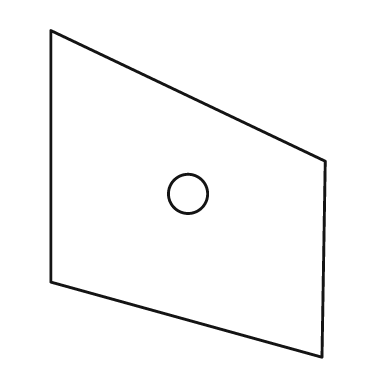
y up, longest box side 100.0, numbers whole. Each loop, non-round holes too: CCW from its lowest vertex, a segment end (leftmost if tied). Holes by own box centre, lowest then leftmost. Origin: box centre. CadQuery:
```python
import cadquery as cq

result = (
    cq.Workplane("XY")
    .moveTo(41.0, -50.0)
    .lineTo(42.0, 10.0)
    .lineTo(-42.0, 50.0)
    .lineTo(-42.0, -27.0)
    .close()
    .moveTo(0.0, 0.0)
    .circle(6.0)
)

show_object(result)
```